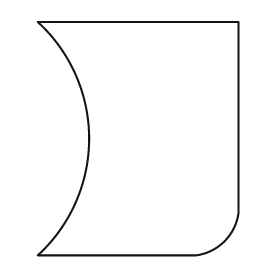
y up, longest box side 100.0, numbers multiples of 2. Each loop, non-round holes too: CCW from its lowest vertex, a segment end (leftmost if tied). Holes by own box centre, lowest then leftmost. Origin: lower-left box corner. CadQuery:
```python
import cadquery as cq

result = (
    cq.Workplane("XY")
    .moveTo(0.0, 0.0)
    .lineTo(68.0, 0.0)
    .threePointArc((80.0, 6.0), (86.0, 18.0))
    .lineTo(86.0, 100.0)
    .lineTo(0.0, 100.0)
    .threePointArc((22.0, 50.0), (0.0, 0.0))
    .close()
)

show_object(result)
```